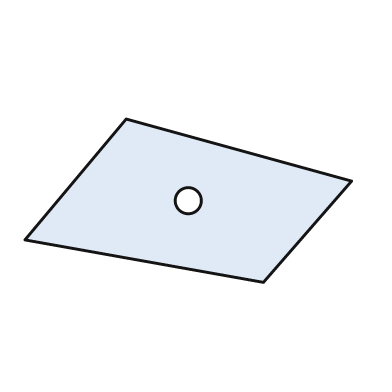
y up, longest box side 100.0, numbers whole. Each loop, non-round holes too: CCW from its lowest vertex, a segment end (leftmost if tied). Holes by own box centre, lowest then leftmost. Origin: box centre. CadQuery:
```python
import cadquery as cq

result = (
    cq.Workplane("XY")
    .moveTo(23.0, -25.0)
    .lineTo(50.0, 6.0)
    .lineTo(-19.0, 25.0)
    .lineTo(-50.0, -12.0)
    .close()
    .moveTo(0.0, 0.0)
    .circle(4.0)
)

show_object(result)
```